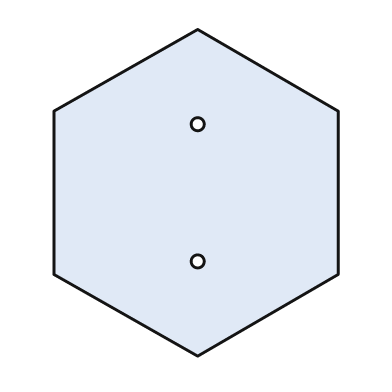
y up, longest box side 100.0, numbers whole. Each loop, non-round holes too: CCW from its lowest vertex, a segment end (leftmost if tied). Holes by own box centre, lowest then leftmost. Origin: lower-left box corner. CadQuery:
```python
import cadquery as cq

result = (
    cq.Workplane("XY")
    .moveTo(44.0, 0.0)
    .lineTo(87.0, 25.0)
    .lineTo(87.0, 75.0)
    .lineTo(44.0, 100.0)
    .lineTo(0.0, 75.0)
    .lineTo(0.0, 25.0)
    .close()
    .moveTo(44.0, 29.0)
    .circle(2.0)
    .moveTo(44.0, 71.0)
    .circle(2.0)
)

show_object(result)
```